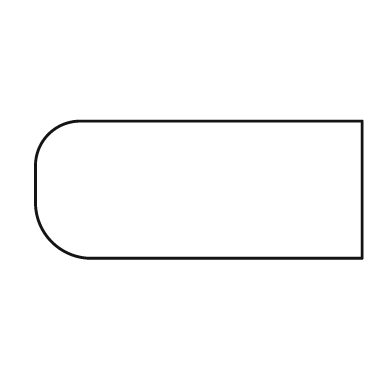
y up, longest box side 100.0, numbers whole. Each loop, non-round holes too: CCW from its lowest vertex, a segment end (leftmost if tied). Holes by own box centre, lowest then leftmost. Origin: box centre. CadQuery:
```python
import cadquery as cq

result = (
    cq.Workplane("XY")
    .moveTo(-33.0, -21.0)
    .lineTo(50.0, -21.0)
    .lineTo(50.0, 21.0)
    .lineTo(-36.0, 21.0)
    .threePointArc((-46.0, 17.0), (-50.0, 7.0))
    .lineTo(-50.0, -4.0)
    .threePointArc((-45.0, -16.0), (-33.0, -21.0))
    .close()
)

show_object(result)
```